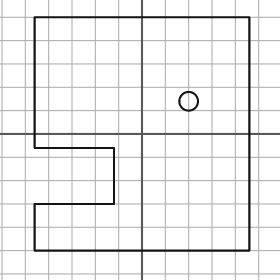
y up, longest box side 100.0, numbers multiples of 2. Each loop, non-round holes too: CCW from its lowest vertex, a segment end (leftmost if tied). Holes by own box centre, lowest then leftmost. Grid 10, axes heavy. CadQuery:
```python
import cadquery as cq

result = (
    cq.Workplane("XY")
    .moveTo(-46.0, -50.0)
    .lineTo(46.0, -50.0)
    .lineTo(46.0, 50.0)
    .lineTo(-46.0, 50.0)
    .lineTo(-46.0, -6.0)
    .lineTo(-12.0, -6.0)
    .lineTo(-12.0, -30.0)
    .lineTo(-46.0, -30.0)
    .close()
    .moveTo(20.0, 14.0)
    .circle(4.0)
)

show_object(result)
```